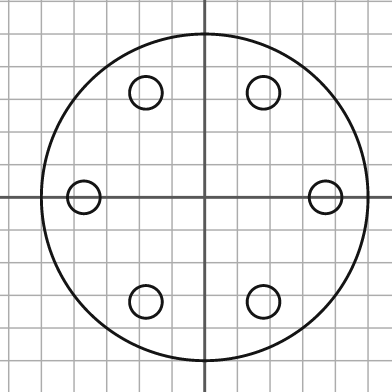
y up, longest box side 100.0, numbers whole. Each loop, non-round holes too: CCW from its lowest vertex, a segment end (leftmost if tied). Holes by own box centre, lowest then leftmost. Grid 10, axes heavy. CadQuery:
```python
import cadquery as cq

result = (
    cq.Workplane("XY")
    .moveTo(0.0, 0.0)
    .circle(50.0)
    .moveTo(-18.0, -32.0)
    .circle(5.0)
    .moveTo(18.0, -32.0)
    .circle(5.0)
    .moveTo(-37.0, 0.0)
    .circle(5.0)
    .moveTo(37.0, 0.0)
    .circle(5.0)
    .moveTo(-18.0, 32.0)
    .circle(5.0)
    .moveTo(18.0, 32.0)
    .circle(5.0)
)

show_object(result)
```